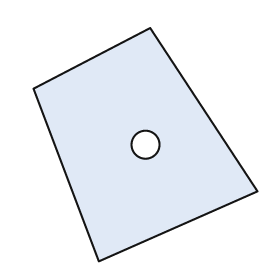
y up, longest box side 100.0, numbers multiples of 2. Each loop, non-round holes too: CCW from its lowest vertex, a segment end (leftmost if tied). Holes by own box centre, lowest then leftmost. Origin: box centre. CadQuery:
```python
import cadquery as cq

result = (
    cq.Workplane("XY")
    .moveTo(-20.0, -50.0)
    .lineTo(48.0, -20.0)
    .lineTo(2.0, 50.0)
    .lineTo(-48.0, 24.0)
    .close()
    .moveTo(0.0, 0.0)
    .circle(6.0)
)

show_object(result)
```